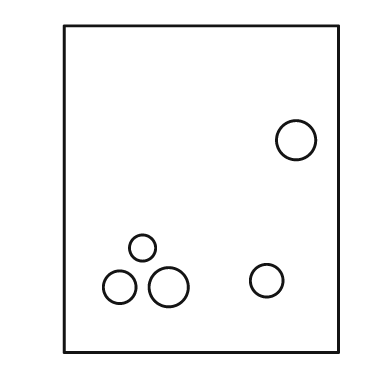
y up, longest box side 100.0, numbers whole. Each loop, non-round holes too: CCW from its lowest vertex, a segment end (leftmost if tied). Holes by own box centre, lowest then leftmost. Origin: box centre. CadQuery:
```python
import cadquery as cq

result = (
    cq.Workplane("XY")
    .moveTo(-42.0, -50.0)
    .lineTo(42.0, -50.0)
    .lineTo(42.0, 50.0)
    .lineTo(-42.0, 50.0)
    .close()
    .moveTo(-25.0, -30.0)
    .circle(5.0)
    .moveTo(-10.0, -30.0)
    .circle(6.0)
    .moveTo(20.0, -28.0)
    .circle(5.0)
    .moveTo(-18.0, -18.0)
    .circle(4.0)
    .moveTo(29.0, 15.0)
    .circle(6.0)
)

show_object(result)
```